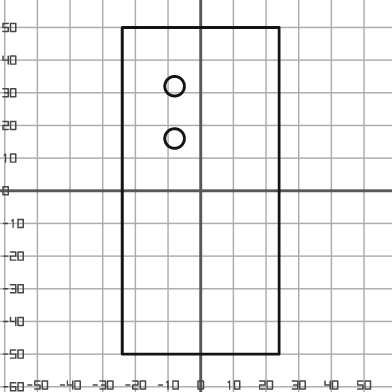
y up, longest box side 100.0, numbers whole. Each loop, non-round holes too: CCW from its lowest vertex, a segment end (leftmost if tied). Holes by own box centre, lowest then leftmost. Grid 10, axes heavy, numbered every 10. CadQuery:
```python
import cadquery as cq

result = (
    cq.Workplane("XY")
    .moveTo(-24.0, -50.0)
    .lineTo(24.0, -50.0)
    .lineTo(24.0, 50.0)
    .lineTo(-24.0, 50.0)
    .close()
    .moveTo(-8.0, 16.0)
    .circle(3.0)
    .moveTo(-8.0, 32.0)
    .circle(3.0)
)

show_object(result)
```